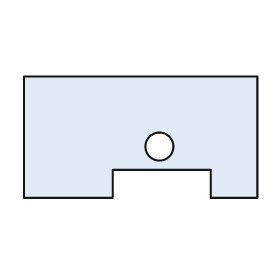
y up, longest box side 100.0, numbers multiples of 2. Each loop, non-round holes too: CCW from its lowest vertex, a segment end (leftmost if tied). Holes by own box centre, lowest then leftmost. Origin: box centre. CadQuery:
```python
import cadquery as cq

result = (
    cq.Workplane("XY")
    .moveTo(-50.0, -26.0)
    .lineTo(-12.0, -26.0)
    .lineTo(-12.0, -14.0)
    .lineTo(30.0, -14.0)
    .lineTo(30.0, -26.0)
    .lineTo(50.0, -26.0)
    .lineTo(50.0, 26.0)
    .lineTo(-50.0, 26.0)
    .close()
    .moveTo(8.0, -4.0)
    .circle(6.0)
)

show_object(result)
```